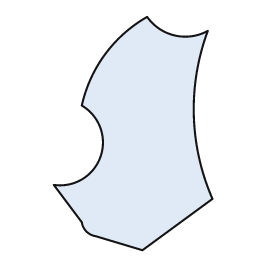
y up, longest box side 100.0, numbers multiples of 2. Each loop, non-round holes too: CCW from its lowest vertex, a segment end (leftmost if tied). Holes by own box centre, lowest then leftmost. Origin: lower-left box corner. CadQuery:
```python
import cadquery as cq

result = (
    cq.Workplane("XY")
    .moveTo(38.0, 0.0)
    .lineTo(68.0, 22.0)
    .threePointArc((60.0, 58.0), (66.0, 94.0))
    .threePointArc((52.0, 92.0), (40.0, 100.0))
    .threePointArc((22.0, 84.0), (12.0, 62.0))
    .threePointArc((20.0, 40.0), (0.0, 28.0))
    .lineTo(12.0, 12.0)
    .threePointArc((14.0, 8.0), (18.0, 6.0))
    .close()
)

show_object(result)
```